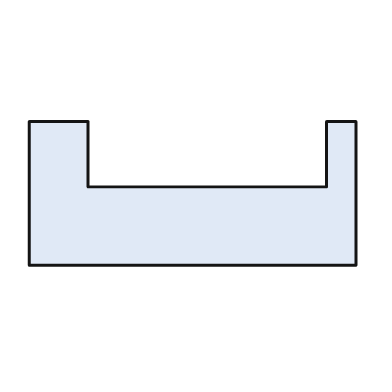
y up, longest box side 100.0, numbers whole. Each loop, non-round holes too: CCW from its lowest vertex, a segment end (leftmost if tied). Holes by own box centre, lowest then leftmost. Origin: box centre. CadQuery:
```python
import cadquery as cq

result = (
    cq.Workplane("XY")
    .moveTo(-50.0, -22.0)
    .lineTo(50.0, -22.0)
    .lineTo(50.0, 22.0)
    .lineTo(41.0, 22.0)
    .lineTo(41.0, 2.0)
    .lineTo(-32.0, 2.0)
    .lineTo(-32.0, 22.0)
    .lineTo(-50.0, 22.0)
    .close()
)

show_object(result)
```